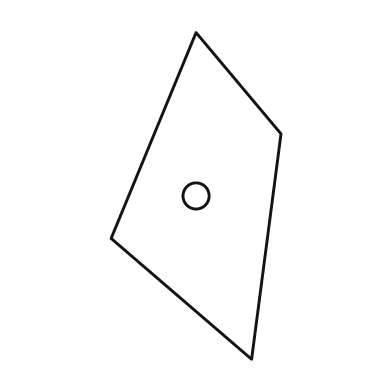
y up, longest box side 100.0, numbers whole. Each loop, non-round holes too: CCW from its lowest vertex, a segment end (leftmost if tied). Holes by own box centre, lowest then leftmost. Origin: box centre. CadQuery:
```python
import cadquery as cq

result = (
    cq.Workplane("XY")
    .moveTo(17.0, -50.0)
    .lineTo(26.0, 19.0)
    .lineTo(0.0, 50.0)
    .lineTo(-26.0, -13.0)
    .close()
    .moveTo(0.0, 0.0)
    .circle(4.0)
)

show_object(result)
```